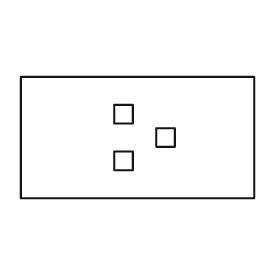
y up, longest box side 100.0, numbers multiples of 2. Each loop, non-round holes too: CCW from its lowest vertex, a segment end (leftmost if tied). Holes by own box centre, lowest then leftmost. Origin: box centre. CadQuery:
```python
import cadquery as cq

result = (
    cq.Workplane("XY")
    .moveTo(-50.0, -26.0)
    .lineTo(50.0, -26.0)
    .lineTo(50.0, 26.0)
    .lineTo(-50.0, 26.0)
    .close()
    .moveTo(-10.0, -14.0)
    .lineTo(-2.0, -14.0)
    .lineTo(-2.0, -6.0)
    .lineTo(-10.0, -6.0)
    .close()
    .moveTo(8.0, -4.0)
    .lineTo(16.0, -4.0)
    .lineTo(16.0, 4.0)
    .lineTo(8.0, 4.0)
    .close()
    .moveTo(-10.0, 6.0)
    .lineTo(-2.0, 6.0)
    .lineTo(-2.0, 14.0)
    .lineTo(-10.0, 14.0)
    .close()
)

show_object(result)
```